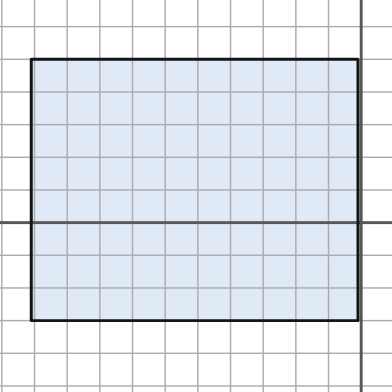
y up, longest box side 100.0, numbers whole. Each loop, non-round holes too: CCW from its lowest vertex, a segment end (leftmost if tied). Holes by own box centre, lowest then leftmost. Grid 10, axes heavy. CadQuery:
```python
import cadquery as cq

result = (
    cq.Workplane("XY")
    .moveTo(-101.0, -30.0)
    .lineTo(-1.0, -30.0)
    .lineTo(-1.0, 50.0)
    .lineTo(-101.0, 50.0)
    .close()
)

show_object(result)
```